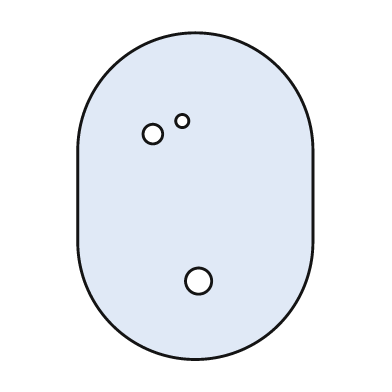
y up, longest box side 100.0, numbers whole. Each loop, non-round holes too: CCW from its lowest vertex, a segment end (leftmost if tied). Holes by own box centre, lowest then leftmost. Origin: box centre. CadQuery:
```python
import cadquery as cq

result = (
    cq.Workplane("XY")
    .moveTo(-36.0, -14.0)
    .threePointArc((0.0, -50.0), (36.0, -14.0))
    .lineTo(36.0, 14.0)
    .threePointArc((0.0, 50.0), (-36.0, 14.0))
    .close()
    .moveTo(1.0, -26.0)
    .circle(4.0)
    .moveTo(-13.0, 19.0)
    .circle(3.0)
    .moveTo(-4.0, 23.0)
    .circle(2.0)
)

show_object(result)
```